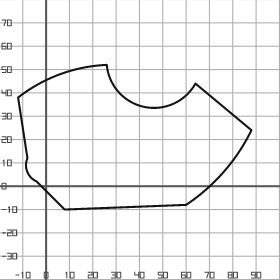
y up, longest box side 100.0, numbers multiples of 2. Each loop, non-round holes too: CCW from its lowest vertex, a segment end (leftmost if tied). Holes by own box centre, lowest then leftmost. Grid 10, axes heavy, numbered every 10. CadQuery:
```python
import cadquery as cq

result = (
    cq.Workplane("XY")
    .moveTo(8.0, -10.0)
    .lineTo(60.0, -8.0)
    .threePointArc((76.0, 6.0), (88.0, 24.0))
    .lineTo(64.0, 44.0)
    .threePointArc((42.0, 34.0), (26.0, 52.0))
    .threePointArc((6.0, 48.0), (-12.0, 38.0))
    .lineTo(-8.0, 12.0)
    .threePointArc((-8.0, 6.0), (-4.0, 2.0))
    .close()
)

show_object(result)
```